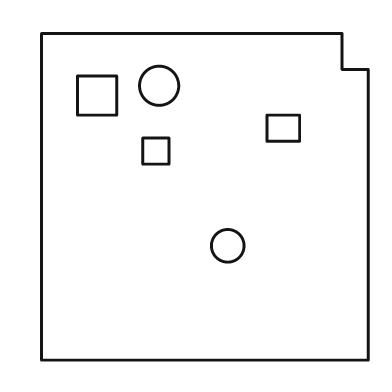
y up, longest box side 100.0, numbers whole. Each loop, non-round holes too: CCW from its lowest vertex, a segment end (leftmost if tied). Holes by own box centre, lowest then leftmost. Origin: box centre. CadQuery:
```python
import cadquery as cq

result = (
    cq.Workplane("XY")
    .moveTo(-50.0, -50.0)
    .lineTo(50.0, -50.0)
    .lineTo(50.0, 39.0)
    .lineTo(42.0, 39.0)
    .lineTo(42.0, 50.0)
    .lineTo(-50.0, 50.0)
    .close()
    .moveTo(7.0, -15.0)
    .circle(5.0)
    .moveTo(-19.0, 10.0)
    .lineTo(-11.0, 10.0)
    .lineTo(-11.0, 18.0)
    .lineTo(-19.0, 18.0)
    .close()
    .moveTo(19.0, 17.0)
    .lineTo(29.0, 17.0)
    .lineTo(29.0, 25.0)
    .lineTo(19.0, 25.0)
    .close()
    .moveTo(-39.0, 25.0)
    .lineTo(-27.0, 25.0)
    .lineTo(-27.0, 37.0)
    .lineTo(-39.0, 37.0)
    .close()
    .moveTo(-14.0, 34.0)
    .circle(6.0)
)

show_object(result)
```